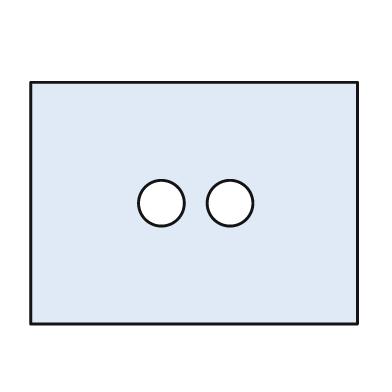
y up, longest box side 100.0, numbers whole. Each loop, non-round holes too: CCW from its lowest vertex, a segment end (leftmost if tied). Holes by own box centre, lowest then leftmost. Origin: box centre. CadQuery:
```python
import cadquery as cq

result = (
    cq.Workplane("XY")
    .moveTo(-50.0, -37.0)
    .lineTo(50.0, -37.0)
    .lineTo(50.0, 37.0)
    .lineTo(-50.0, 37.0)
    .close()
    .moveTo(-10.0, 0.0)
    .circle(7.0)
    .moveTo(11.0, 0.0)
    .circle(7.0)
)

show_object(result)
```